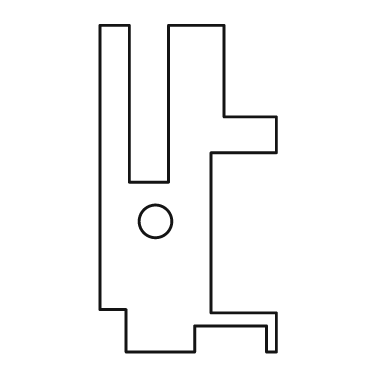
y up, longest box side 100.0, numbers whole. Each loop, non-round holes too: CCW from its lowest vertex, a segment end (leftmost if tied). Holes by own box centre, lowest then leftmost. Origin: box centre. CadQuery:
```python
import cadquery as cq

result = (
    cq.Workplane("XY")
    .moveTo(-19.0, -50.0)
    .lineTo(2.0, -50.0)
    .lineTo(2.0, -42.0)
    .lineTo(24.0, -42.0)
    .lineTo(24.0, -50.0)
    .lineTo(27.0, -50.0)
    .lineTo(27.0, -38.0)
    .lineTo(7.0, -38.0)
    .lineTo(7.0, 11.0)
    .lineTo(27.0, 11.0)
    .lineTo(27.0, 22.0)
    .lineTo(11.0, 22.0)
    .lineTo(11.0, 50.0)
    .lineTo(-6.0, 50.0)
    .lineTo(-6.0, 2.0)
    .lineTo(-18.0, 2.0)
    .lineTo(-18.0, 50.0)
    .lineTo(-27.0, 50.0)
    .lineTo(-27.0, -37.0)
    .lineTo(-19.0, -37.0)
    .close()
    .moveTo(-10.0, -10.0)
    .circle(5.0)
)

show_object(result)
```